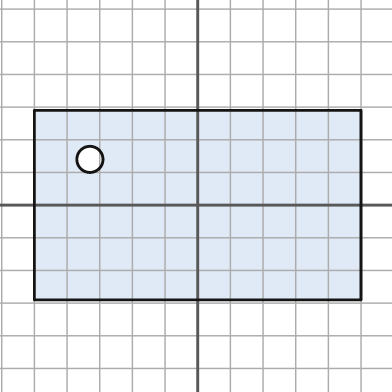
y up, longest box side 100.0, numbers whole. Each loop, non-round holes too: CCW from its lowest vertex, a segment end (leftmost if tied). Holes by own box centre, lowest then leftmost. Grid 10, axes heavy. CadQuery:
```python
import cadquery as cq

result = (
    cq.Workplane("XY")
    .moveTo(-50.0, -29.0)
    .lineTo(50.0, -29.0)
    .lineTo(50.0, 29.0)
    .lineTo(-50.0, 29.0)
    .close()
    .moveTo(-33.0, 14.0)
    .circle(4.0)
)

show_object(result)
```